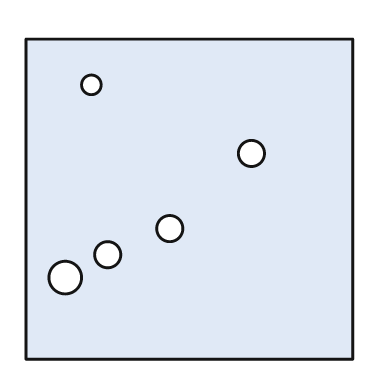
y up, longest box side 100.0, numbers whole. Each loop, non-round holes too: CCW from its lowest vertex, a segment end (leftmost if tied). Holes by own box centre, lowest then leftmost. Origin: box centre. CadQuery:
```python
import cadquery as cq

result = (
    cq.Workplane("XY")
    .moveTo(-50.0, -49.0)
    .lineTo(50.0, -49.0)
    .lineTo(50.0, 49.0)
    .lineTo(-50.0, 49.0)
    .close()
    .moveTo(-38.0, -24.0)
    .circle(5.0)
    .moveTo(-25.0, -17.0)
    .circle(4.0)
    .moveTo(-6.0, -9.0)
    .circle(4.0)
    .moveTo(19.0, 14.0)
    .circle(4.0)
    .moveTo(-30.0, 35.0)
    .circle(3.0)
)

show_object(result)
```